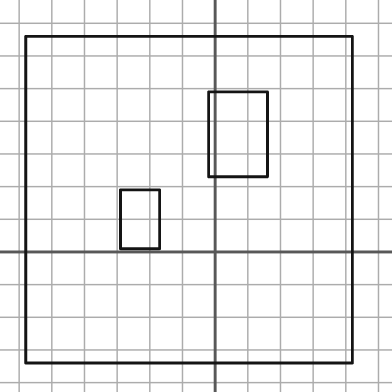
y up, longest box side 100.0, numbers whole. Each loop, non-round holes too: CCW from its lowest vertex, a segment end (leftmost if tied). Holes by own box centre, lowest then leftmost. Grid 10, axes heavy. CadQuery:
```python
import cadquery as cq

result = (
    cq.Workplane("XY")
    .moveTo(-58.0, -34.0)
    .lineTo(42.0, -34.0)
    .lineTo(42.0, 66.0)
    .lineTo(-58.0, 66.0)
    .close()
    .moveTo(-29.0, 1.0)
    .lineTo(-17.0, 1.0)
    .lineTo(-17.0, 19.0)
    .lineTo(-29.0, 19.0)
    .close()
    .moveTo(-2.0, 23.0)
    .lineTo(16.0, 23.0)
    .lineTo(16.0, 49.0)
    .lineTo(-2.0, 49.0)
    .close()
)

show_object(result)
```